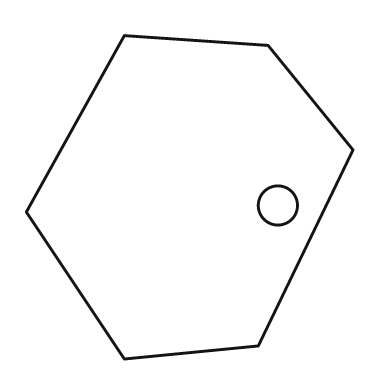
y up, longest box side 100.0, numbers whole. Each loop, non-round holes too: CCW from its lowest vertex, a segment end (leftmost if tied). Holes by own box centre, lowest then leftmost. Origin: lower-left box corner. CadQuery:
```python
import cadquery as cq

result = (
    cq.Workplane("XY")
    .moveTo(30.0, 0.0)
    .lineTo(71.0, 4.0)
    .lineTo(100.0, 64.0)
    .lineTo(74.0, 96.0)
    .lineTo(30.0, 99.0)
    .lineTo(0.0, 45.0)
    .close()
    .moveTo(77.0, 47.0)
    .circle(6.0)
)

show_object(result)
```